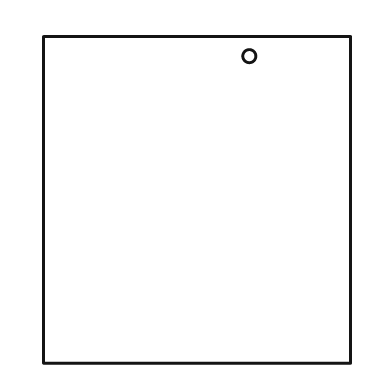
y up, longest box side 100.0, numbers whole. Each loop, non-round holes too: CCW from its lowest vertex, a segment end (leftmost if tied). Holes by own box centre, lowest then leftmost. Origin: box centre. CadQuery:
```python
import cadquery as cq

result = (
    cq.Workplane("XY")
    .moveTo(-47.0, -50.0)
    .lineTo(47.0, -50.0)
    .lineTo(47.0, 50.0)
    .lineTo(-47.0, 50.0)
    .close()
    .moveTo(16.0, 44.0)
    .circle(2.0)
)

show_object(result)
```